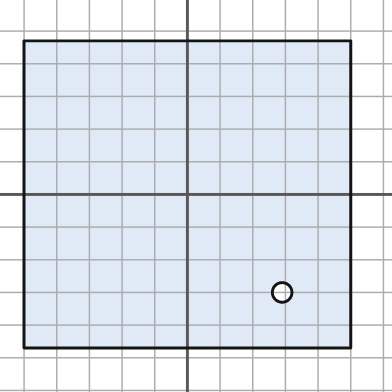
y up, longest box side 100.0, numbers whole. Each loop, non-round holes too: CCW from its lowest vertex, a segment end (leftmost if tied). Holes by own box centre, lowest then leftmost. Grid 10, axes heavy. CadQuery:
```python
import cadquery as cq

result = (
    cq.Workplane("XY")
    .moveTo(-50.0, -47.0)
    .lineTo(50.0, -47.0)
    .lineTo(50.0, 47.0)
    .lineTo(-50.0, 47.0)
    .close()
    .moveTo(29.0, -30.0)
    .circle(3.0)
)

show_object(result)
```